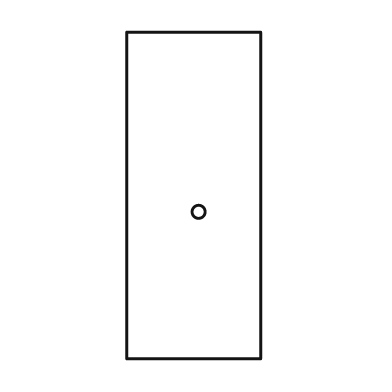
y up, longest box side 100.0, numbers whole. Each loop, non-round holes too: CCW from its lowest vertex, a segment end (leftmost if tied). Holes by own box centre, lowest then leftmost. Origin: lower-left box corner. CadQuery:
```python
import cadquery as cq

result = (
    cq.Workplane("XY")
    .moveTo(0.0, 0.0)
    .lineTo(41.0, 0.0)
    .lineTo(41.0, 100.0)
    .lineTo(0.0, 100.0)
    .close()
    .moveTo(22.0, 45.0)
    .circle(2.0)
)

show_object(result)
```